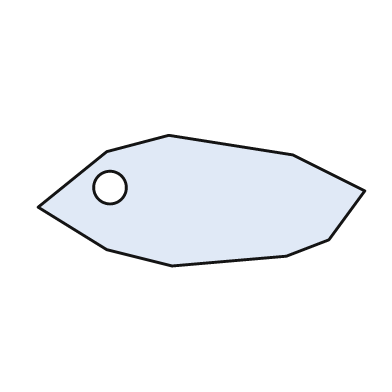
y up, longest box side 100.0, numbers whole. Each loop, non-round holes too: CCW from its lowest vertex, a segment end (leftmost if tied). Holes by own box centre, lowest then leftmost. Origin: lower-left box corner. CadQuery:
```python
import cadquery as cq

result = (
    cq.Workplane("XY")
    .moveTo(41.0, 0.0)
    .lineTo(76.0, 3.0)
    .lineTo(89.0, 8.0)
    .lineTo(100.0, 23.0)
    .lineTo(78.0, 34.0)
    .lineTo(40.0, 40.0)
    .lineTo(21.0, 35.0)
    .lineTo(0.0, 18.0)
    .lineTo(21.0, 5.0)
    .close()
    .moveTo(22.0, 24.0)
    .circle(5.0)
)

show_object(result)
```